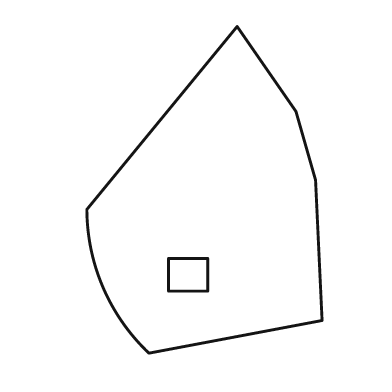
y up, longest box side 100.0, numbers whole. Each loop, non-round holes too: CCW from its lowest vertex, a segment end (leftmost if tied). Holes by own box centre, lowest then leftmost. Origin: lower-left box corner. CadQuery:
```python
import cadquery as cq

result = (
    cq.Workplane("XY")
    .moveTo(19.0, 0.0)
    .lineTo(72.0, 10.0)
    .lineTo(70.0, 53.0)
    .lineTo(64.0, 74.0)
    .lineTo(46.0, 100.0)
    .lineTo(0.0, 44.0)
    .threePointArc((5.0, 20.0), (19.0, 0.0))
    .close()
    .moveTo(25.0, 19.0)
    .lineTo(37.0, 19.0)
    .lineTo(37.0, 29.0)
    .lineTo(25.0, 29.0)
    .close()
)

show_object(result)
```